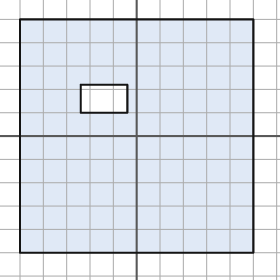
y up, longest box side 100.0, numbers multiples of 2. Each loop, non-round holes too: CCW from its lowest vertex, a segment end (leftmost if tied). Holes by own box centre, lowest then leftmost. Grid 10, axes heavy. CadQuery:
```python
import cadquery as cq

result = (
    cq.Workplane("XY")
    .moveTo(-50.0, -50.0)
    .lineTo(50.0, -50.0)
    .lineTo(50.0, 50.0)
    .lineTo(-50.0, 50.0)
    .close()
    .moveTo(-24.0, 10.0)
    .lineTo(-4.0, 10.0)
    .lineTo(-4.0, 22.0)
    .lineTo(-24.0, 22.0)
    .close()
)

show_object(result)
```